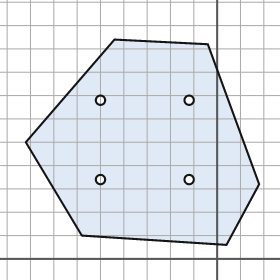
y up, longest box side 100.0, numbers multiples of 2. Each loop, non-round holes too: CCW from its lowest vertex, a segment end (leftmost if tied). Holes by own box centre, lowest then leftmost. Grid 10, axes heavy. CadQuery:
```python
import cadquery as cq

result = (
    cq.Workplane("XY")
    .moveTo(4.0, 6.0)
    .lineTo(18.0, 32.0)
    .lineTo(-4.0, 92.0)
    .lineTo(-44.0, 94.0)
    .lineTo(-82.0, 50.0)
    .lineTo(-58.0, 10.0)
    .close()
    .moveTo(-50.0, 34.0)
    .circle(2.0)
    .moveTo(-12.0, 34.0)
    .circle(2.0)
    .moveTo(-50.0, 68.0)
    .circle(2.0)
    .moveTo(-12.0, 68.0)
    .circle(2.0)
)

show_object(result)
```